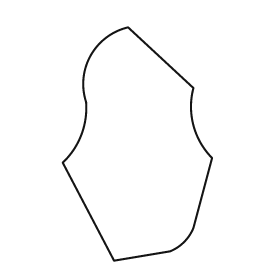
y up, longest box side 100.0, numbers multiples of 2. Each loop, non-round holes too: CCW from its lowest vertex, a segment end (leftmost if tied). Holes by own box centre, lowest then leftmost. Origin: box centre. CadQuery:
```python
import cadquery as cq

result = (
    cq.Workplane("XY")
    .moveTo(-10.0, -50.0)
    .lineTo(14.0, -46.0)
    .threePointArc((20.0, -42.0), (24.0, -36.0))
    .lineTo(32.0, -6.0)
    .threePointArc((24.0, 8.0), (24.0, 24.0))
    .lineTo(-4.0, 50.0)
    .threePointArc((-20.0, 38.0), (-22.0, 18.0))
    .threePointArc((-24.0, 4.0), (-32.0, -8.0))
    .close()
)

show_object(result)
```